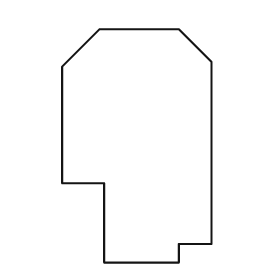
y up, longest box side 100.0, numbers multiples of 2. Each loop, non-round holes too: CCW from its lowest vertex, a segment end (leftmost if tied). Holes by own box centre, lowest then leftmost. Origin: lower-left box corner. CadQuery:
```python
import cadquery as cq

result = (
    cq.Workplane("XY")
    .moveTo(18.0, 0.0)
    .lineTo(50.0, 0.0)
    .lineTo(50.0, 8.0)
    .lineTo(64.0, 8.0)
    .lineTo(64.0, 86.0)
    .lineTo(50.0, 100.0)
    .lineTo(16.0, 100.0)
    .lineTo(0.0, 84.0)
    .lineTo(0.0, 34.0)
    .lineTo(18.0, 34.0)
    .close()
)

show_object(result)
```